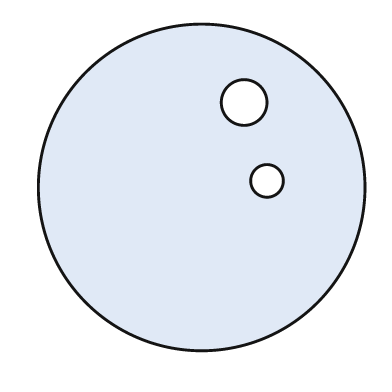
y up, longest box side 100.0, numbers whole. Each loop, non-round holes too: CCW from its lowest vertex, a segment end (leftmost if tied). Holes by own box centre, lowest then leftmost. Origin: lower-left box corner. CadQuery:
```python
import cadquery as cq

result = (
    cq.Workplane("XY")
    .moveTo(50.0, 50.0)
    .circle(50.0)
    .moveTo(70.0, 52.0)
    .circle(5.0)
    .moveTo(63.0, 76.0)
    .circle(7.0)
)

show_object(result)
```